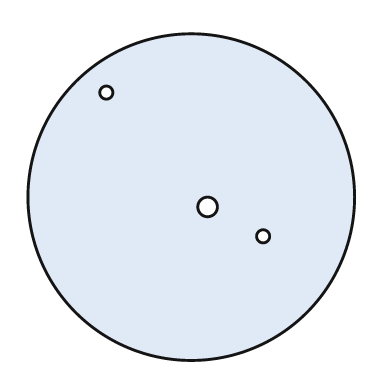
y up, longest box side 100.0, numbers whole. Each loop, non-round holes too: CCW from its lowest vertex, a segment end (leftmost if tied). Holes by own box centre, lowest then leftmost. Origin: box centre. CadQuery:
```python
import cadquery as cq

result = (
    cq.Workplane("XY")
    .moveTo(0.0, 0.0)
    .circle(50.0)
    .moveTo(22.0, -12.0)
    .circle(2.0)
    .moveTo(5.0, -3.0)
    .circle(3.0)
    .moveTo(-26.0, 32.0)
    .circle(2.0)
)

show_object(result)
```